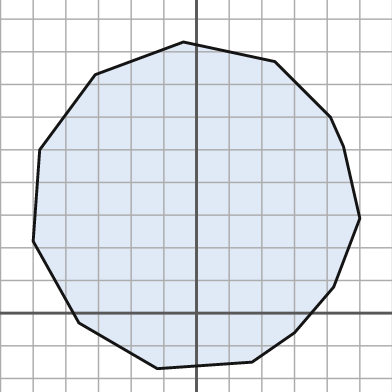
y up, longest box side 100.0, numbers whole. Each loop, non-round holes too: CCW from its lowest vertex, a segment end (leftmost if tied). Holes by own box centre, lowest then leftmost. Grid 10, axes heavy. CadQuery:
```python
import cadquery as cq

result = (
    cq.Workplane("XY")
    .moveTo(-12.0, -17.0)
    .lineTo(17.0, -15.0)
    .lineTo(30.0, -6.0)
    .lineTo(42.0, 8.0)
    .lineTo(50.0, 29.0)
    .lineTo(45.0, 51.0)
    .lineTo(41.0, 60.0)
    .lineTo(24.0, 77.0)
    .lineTo(-4.0, 83.0)
    .lineTo(-31.0, 73.0)
    .lineTo(-48.0, 50.0)
    .lineTo(-50.0, 22.0)
    .lineTo(-36.0, -3.0)
    .close()
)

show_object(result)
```